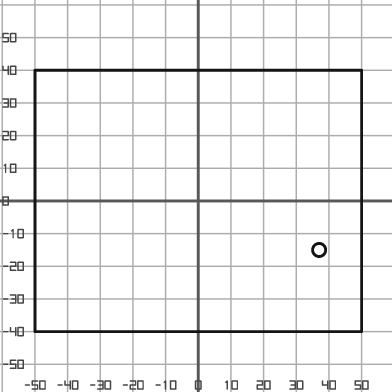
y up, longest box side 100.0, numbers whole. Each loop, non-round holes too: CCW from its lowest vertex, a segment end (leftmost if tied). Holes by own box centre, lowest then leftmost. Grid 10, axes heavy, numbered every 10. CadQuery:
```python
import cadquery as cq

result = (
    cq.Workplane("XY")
    .moveTo(-50.0, -40.0)
    .lineTo(50.0, -40.0)
    .lineTo(50.0, 40.0)
    .lineTo(-50.0, 40.0)
    .close()
    .moveTo(37.0, -15.0)
    .circle(2.0)
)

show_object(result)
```